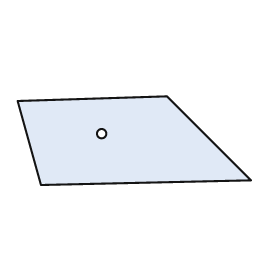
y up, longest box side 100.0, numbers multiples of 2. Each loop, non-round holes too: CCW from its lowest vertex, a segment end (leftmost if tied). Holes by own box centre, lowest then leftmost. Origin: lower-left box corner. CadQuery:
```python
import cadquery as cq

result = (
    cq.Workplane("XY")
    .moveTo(10.0, 0.0)
    .lineTo(100.0, 2.0)
    .lineTo(64.0, 38.0)
    .lineTo(0.0, 36.0)
    .close()
    .moveTo(36.0, 22.0)
    .circle(2.0)
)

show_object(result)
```